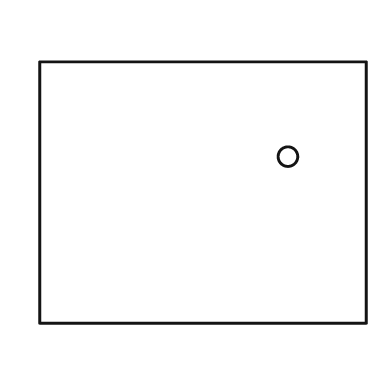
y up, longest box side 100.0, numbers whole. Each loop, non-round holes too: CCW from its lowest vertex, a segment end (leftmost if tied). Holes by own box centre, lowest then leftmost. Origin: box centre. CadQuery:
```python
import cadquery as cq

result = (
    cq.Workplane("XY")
    .moveTo(-50.0, -40.0)
    .lineTo(50.0, -40.0)
    .lineTo(50.0, 40.0)
    .lineTo(-50.0, 40.0)
    .close()
    .moveTo(26.0, 11.0)
    .circle(3.0)
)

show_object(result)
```